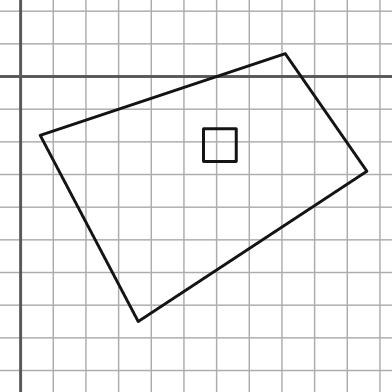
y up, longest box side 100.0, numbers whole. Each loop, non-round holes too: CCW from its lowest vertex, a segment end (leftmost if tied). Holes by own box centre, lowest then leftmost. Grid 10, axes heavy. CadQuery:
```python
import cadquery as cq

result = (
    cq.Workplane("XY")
    .moveTo(36.0, -75.0)
    .lineTo(106.0, -29.0)
    .lineTo(81.0, 7.0)
    .lineTo(6.0, -18.0)
    .close()
    .moveTo(56.0, -26.0)
    .lineTo(66.0, -26.0)
    .lineTo(66.0, -16.0)
    .lineTo(56.0, -16.0)
    .close()
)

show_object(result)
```